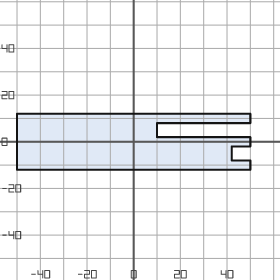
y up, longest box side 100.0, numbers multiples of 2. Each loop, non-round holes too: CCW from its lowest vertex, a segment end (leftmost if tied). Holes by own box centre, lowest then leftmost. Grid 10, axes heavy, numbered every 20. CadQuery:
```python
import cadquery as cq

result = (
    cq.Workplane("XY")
    .moveTo(-50.0, -12.0)
    .lineTo(50.0, -12.0)
    .lineTo(50.0, -8.0)
    .lineTo(42.0, -8.0)
    .lineTo(42.0, -2.0)
    .lineTo(50.0, -2.0)
    .lineTo(50.0, 2.0)
    .lineTo(10.0, 2.0)
    .lineTo(10.0, 8.0)
    .lineTo(50.0, 8.0)
    .lineTo(50.0, 12.0)
    .lineTo(-50.0, 12.0)
    .close()
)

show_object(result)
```